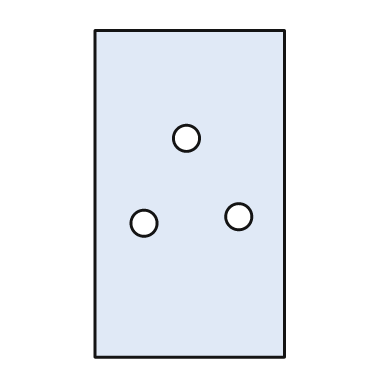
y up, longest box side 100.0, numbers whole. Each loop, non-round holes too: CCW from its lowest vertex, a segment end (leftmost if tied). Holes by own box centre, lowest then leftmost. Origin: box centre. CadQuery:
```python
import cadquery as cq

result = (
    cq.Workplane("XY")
    .moveTo(-29.0, -50.0)
    .lineTo(29.0, -50.0)
    .lineTo(29.0, 50.0)
    .lineTo(-29.0, 50.0)
    .close()
    .moveTo(-14.0, -9.0)
    .circle(4.0)
    .moveTo(15.0, -7.0)
    .circle(4.0)
    .moveTo(-1.0, 17.0)
    .circle(4.0)
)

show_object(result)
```